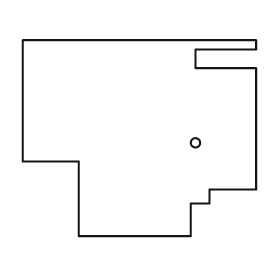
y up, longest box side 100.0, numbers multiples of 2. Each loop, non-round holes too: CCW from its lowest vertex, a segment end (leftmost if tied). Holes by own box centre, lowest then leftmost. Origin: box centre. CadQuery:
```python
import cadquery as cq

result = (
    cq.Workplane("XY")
    .moveTo(-26.0, -42.0)
    .lineTo(22.0, -42.0)
    .lineTo(22.0, -28.0)
    .lineTo(30.0, -28.0)
    .lineTo(30.0, -22.0)
    .lineTo(50.0, -22.0)
    .lineTo(50.0, 30.0)
    .lineTo(24.0, 30.0)
    .lineTo(24.0, 38.0)
    .lineTo(50.0, 38.0)
    .lineTo(50.0, 42.0)
    .lineTo(-50.0, 42.0)
    .lineTo(-50.0, -10.0)
    .lineTo(-26.0, -10.0)
    .close()
    .moveTo(24.0, -2.0)
    .circle(2.0)
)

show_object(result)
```